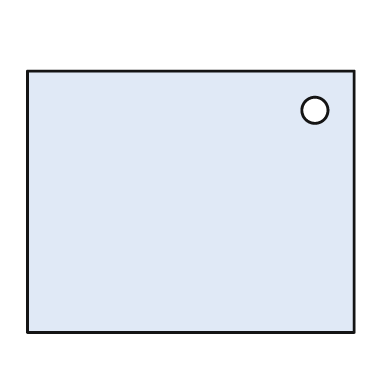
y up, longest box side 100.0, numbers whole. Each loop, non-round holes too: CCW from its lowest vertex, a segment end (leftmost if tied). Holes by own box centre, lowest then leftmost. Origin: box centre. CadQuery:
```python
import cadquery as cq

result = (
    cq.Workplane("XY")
    .moveTo(-50.0, -40.0)
    .lineTo(50.0, -40.0)
    .lineTo(50.0, 40.0)
    .lineTo(-50.0, 40.0)
    .close()
    .moveTo(38.0, 28.0)
    .circle(4.0)
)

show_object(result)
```